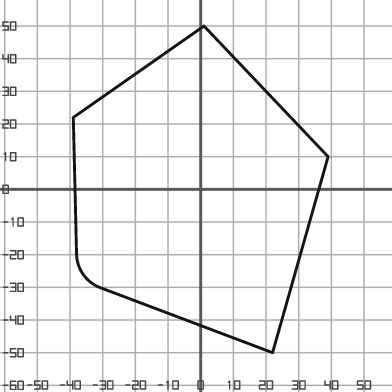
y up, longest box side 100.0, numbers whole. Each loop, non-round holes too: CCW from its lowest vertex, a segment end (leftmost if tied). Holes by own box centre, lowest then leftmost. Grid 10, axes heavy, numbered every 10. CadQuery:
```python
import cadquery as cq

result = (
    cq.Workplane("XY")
    .moveTo(22.0, -50.0)
    .lineTo(39.0, 10.0)
    .lineTo(1.0, 50.0)
    .lineTo(-39.0, 22.0)
    .lineTo(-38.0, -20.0)
    .threePointArc((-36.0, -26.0), (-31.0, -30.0))
    .close()
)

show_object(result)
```